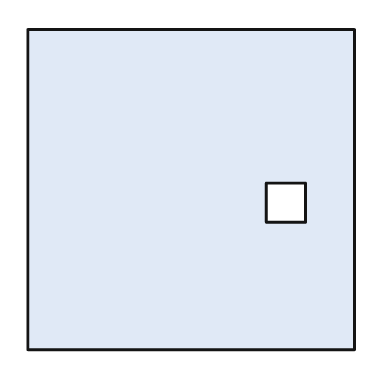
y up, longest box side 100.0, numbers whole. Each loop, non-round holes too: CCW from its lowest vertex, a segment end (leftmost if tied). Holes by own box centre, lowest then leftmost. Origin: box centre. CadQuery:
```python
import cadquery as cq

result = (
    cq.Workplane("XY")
    .moveTo(-50.0, -49.0)
    .lineTo(50.0, -49.0)
    .lineTo(50.0, 49.0)
    .lineTo(-50.0, 49.0)
    .close()
    .moveTo(23.0, -10.0)
    .lineTo(35.0, -10.0)
    .lineTo(35.0, 2.0)
    .lineTo(23.0, 2.0)
    .close()
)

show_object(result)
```